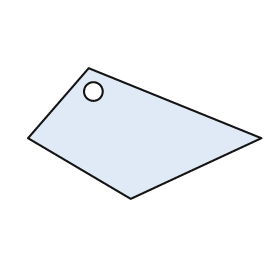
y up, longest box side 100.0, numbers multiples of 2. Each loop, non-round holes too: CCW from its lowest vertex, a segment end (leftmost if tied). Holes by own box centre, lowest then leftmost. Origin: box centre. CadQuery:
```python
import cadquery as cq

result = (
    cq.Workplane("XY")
    .moveTo(-6.0, -28.0)
    .lineTo(50.0, -2.0)
    .lineTo(-24.0, 28.0)
    .lineTo(-50.0, -2.0)
    .close()
    .moveTo(-22.0, 18.0)
    .circle(4.0)
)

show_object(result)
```